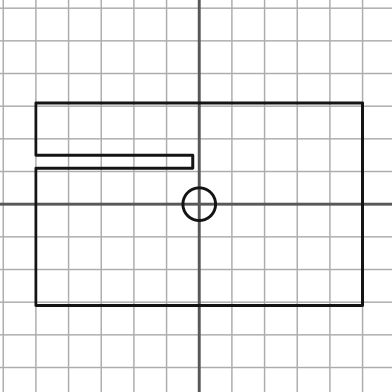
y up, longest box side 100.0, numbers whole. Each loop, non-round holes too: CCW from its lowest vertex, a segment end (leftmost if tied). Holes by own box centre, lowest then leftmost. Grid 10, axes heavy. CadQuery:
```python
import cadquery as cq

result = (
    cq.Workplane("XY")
    .moveTo(-50.0, -31.0)
    .lineTo(50.0, -31.0)
    .lineTo(50.0, 31.0)
    .lineTo(-50.0, 31.0)
    .lineTo(-50.0, 15.0)
    .lineTo(-2.0, 15.0)
    .lineTo(-2.0, 11.0)
    .lineTo(-50.0, 11.0)
    .close()
    .moveTo(0.0, 0.0)
    .circle(5.0)
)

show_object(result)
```